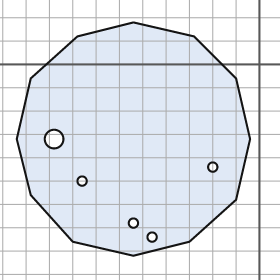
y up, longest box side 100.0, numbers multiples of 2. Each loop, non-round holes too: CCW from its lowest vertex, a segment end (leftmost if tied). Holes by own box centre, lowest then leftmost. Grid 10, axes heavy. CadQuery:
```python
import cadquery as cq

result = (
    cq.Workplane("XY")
    .moveTo(-54.0, -82.0)
    .lineTo(-30.0, -76.0)
    .lineTo(-10.0, -58.0)
    .lineTo(-4.0, -32.0)
    .lineTo(-10.0, -6.0)
    .lineTo(-28.0, 12.0)
    .lineTo(-54.0, 18.0)
    .lineTo(-78.0, 12.0)
    .lineTo(-98.0, -6.0)
    .lineTo(-104.0, -32.0)
    .lineTo(-98.0, -56.0)
    .lineTo(-80.0, -76.0)
    .close()
    .moveTo(-46.0, -74.0)
    .circle(2.0)
    .moveTo(-54.0, -68.0)
    .circle(2.0)
    .moveTo(-76.0, -50.0)
    .circle(2.0)
    .moveTo(-20.0, -44.0)
    .circle(2.0)
    .moveTo(-88.0, -32.0)
    .circle(4.0)
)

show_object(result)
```